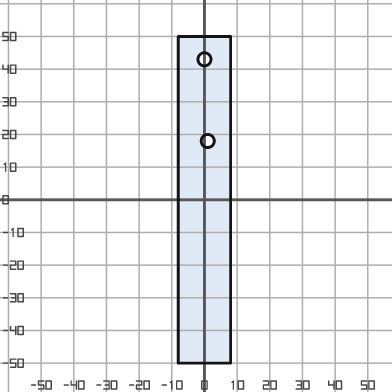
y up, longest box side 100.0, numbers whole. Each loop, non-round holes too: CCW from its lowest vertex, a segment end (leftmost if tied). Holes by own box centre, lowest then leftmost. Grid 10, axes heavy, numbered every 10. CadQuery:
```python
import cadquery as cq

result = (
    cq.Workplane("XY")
    .moveTo(-8.0, -50.0)
    .lineTo(8.0, -50.0)
    .lineTo(8.0, 50.0)
    .lineTo(-8.0, 50.0)
    .close()
    .moveTo(1.0, 18.0)
    .circle(2.0)
    .moveTo(0.0, 43.0)
    .circle(2.0)
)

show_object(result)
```